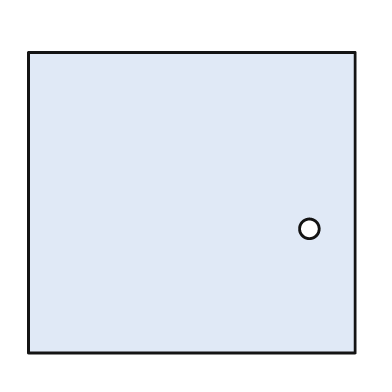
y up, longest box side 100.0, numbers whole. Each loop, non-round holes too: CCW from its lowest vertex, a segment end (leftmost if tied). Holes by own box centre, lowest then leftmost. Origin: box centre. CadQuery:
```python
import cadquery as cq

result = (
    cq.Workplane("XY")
    .moveTo(-50.0, -46.0)
    .lineTo(50.0, -46.0)
    .lineTo(50.0, 46.0)
    .lineTo(-50.0, 46.0)
    .close()
    .moveTo(36.0, -8.0)
    .circle(3.0)
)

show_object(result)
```